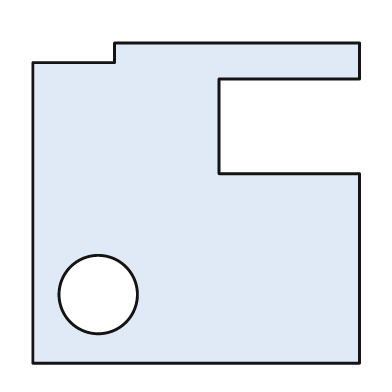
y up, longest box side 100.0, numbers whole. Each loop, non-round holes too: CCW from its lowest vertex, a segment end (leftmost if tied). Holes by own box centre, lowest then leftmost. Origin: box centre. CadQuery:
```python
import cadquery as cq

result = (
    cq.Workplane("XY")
    .moveTo(-50.0, -49.0)
    .lineTo(50.0, -49.0)
    .lineTo(50.0, 9.0)
    .lineTo(7.0, 9.0)
    .lineTo(7.0, 38.0)
    .lineTo(50.0, 38.0)
    .lineTo(50.0, 49.0)
    .lineTo(-25.0, 49.0)
    .lineTo(-25.0, 43.0)
    .lineTo(-50.0, 43.0)
    .close()
    .moveTo(-30.0, -28.0)
    .circle(12.0)
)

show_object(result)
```